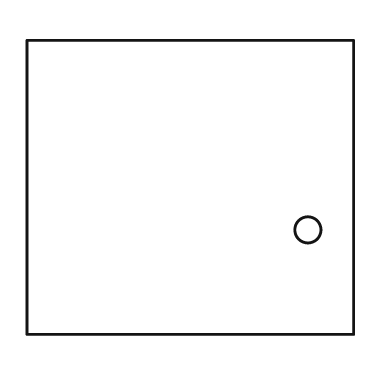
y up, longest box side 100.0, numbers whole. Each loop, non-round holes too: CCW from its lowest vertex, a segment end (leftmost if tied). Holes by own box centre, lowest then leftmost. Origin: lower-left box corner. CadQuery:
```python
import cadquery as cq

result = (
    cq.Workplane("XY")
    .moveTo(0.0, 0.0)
    .lineTo(100.0, 0.0)
    .lineTo(100.0, 90.0)
    .lineTo(0.0, 90.0)
    .close()
    .moveTo(86.0, 32.0)
    .circle(4.0)
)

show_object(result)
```